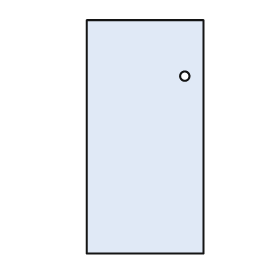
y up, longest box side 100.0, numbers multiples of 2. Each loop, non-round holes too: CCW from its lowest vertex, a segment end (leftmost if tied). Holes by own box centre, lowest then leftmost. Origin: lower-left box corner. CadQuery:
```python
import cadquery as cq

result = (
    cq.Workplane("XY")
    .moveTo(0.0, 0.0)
    .lineTo(50.0, 0.0)
    .lineTo(50.0, 100.0)
    .lineTo(0.0, 100.0)
    .close()
    .moveTo(42.0, 76.0)
    .circle(2.0)
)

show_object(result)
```